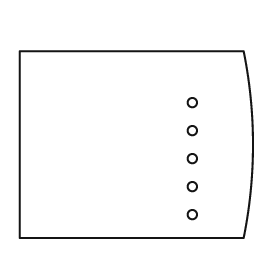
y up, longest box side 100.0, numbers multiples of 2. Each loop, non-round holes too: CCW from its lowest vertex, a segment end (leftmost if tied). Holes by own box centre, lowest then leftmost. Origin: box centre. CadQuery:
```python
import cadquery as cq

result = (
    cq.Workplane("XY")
    .moveTo(-50.0, -40.0)
    .lineTo(46.0, -40.0)
    .threePointArc((50.0, 0.0), (46.0, 40.0))
    .lineTo(-50.0, 40.0)
    .close()
    .moveTo(24.0, -30.0)
    .circle(2.0)
    .moveTo(24.0, -18.0)
    .circle(2.0)
    .moveTo(24.0, -6.0)
    .circle(2.0)
    .moveTo(24.0, 6.0)
    .circle(2.0)
    .moveTo(24.0, 18.0)
    .circle(2.0)
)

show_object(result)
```